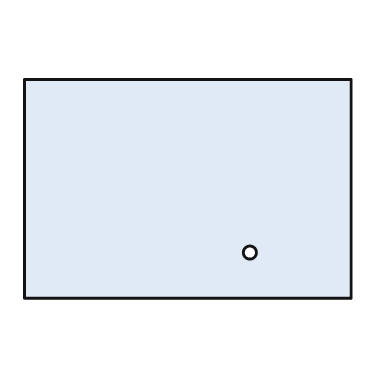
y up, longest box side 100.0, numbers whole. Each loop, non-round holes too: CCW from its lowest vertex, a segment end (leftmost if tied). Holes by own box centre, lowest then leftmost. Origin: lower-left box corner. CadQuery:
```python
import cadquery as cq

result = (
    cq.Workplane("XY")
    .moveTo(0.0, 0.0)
    .lineTo(100.0, 0.0)
    .lineTo(100.0, 67.0)
    .lineTo(0.0, 67.0)
    .close()
    .moveTo(69.0, 14.0)
    .circle(2.0)
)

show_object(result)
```